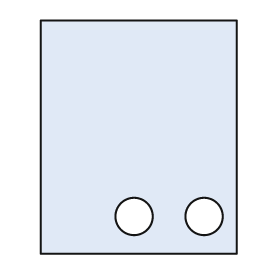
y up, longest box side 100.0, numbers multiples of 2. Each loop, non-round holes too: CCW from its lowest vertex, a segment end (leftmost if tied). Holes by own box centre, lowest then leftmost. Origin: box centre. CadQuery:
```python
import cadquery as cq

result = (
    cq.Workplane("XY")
    .moveTo(-42.0, -50.0)
    .lineTo(42.0, -50.0)
    .lineTo(42.0, 50.0)
    .lineTo(-42.0, 50.0)
    .close()
    .moveTo(-2.0, -34.0)
    .circle(8.0)
    .moveTo(28.0, -34.0)
    .circle(8.0)
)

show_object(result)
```